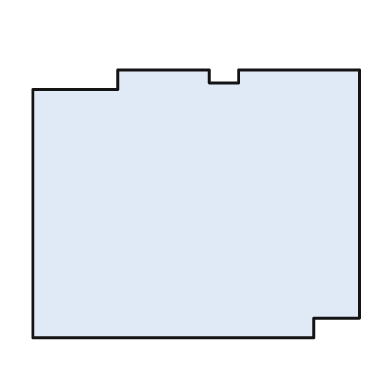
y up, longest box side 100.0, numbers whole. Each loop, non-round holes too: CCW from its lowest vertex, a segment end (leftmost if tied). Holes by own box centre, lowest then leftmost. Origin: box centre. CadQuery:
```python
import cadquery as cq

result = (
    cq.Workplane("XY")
    .moveTo(-50.0, -41.0)
    .lineTo(36.0, -41.0)
    .lineTo(36.0, -35.0)
    .lineTo(50.0, -35.0)
    .lineTo(50.0, 41.0)
    .lineTo(13.0, 41.0)
    .lineTo(13.0, 37.0)
    .lineTo(4.0, 37.0)
    .lineTo(4.0, 41.0)
    .lineTo(-24.0, 41.0)
    .lineTo(-24.0, 35.0)
    .lineTo(-50.0, 35.0)
    .close()
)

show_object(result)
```